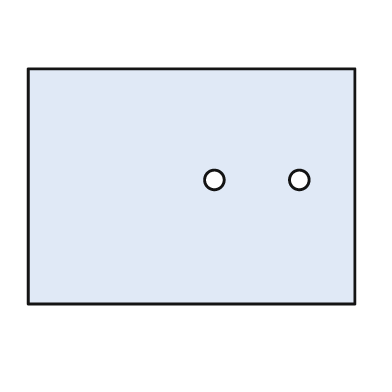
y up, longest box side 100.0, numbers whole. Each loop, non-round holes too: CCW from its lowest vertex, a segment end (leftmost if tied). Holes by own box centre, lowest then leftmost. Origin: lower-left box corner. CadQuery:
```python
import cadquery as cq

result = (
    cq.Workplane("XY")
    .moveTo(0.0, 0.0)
    .lineTo(100.0, 0.0)
    .lineTo(100.0, 72.0)
    .lineTo(0.0, 72.0)
    .close()
    .moveTo(57.0, 38.0)
    .circle(3.0)
    .moveTo(83.0, 38.0)
    .circle(3.0)
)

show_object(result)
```